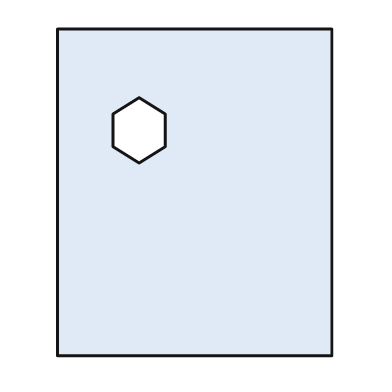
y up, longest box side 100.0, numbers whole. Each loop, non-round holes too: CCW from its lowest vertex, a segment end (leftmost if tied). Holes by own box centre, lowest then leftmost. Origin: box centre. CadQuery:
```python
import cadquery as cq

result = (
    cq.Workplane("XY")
    .moveTo(-42.0, -50.0)
    .lineTo(42.0, -50.0)
    .lineTo(42.0, 50.0)
    .lineTo(-42.0, 50.0)
    .close()
    .moveTo(-17.0, 9.0)
    .lineTo(-9.0, 14.0)
    .lineTo(-9.0, 24.0)
    .lineTo(-17.0, 29.0)
    .lineTo(-25.0, 24.0)
    .lineTo(-25.0, 14.0)
    .close()
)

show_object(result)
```